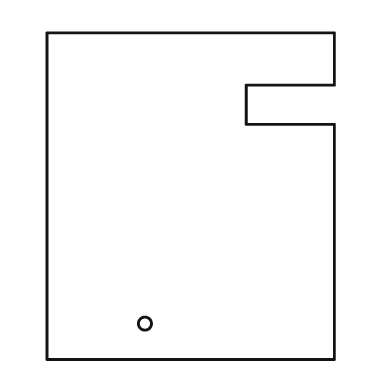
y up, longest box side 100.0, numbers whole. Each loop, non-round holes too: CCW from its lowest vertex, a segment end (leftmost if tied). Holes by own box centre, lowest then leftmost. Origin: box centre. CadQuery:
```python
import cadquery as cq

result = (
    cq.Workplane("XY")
    .moveTo(-44.0, -50.0)
    .lineTo(44.0, -50.0)
    .lineTo(44.0, 22.0)
    .lineTo(17.0, 22.0)
    .lineTo(17.0, 34.0)
    .lineTo(44.0, 34.0)
    .lineTo(44.0, 50.0)
    .lineTo(-44.0, 50.0)
    .close()
    .moveTo(-14.0, -39.0)
    .circle(2.0)
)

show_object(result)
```